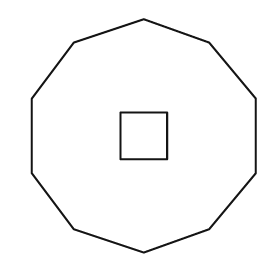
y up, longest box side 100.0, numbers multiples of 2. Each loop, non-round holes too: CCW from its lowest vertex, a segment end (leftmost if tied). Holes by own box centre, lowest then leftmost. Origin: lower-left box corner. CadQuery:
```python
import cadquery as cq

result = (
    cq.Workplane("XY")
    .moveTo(48.0, 0.0)
    .lineTo(76.0, 10.0)
    .lineTo(96.0, 34.0)
    .lineTo(96.0, 66.0)
    .lineTo(76.0, 90.0)
    .lineTo(48.0, 100.0)
    .lineTo(18.0, 90.0)
    .lineTo(0.0, 66.0)
    .lineTo(0.0, 34.0)
    .lineTo(18.0, 10.0)
    .close()
    .moveTo(38.0, 40.0)
    .lineTo(58.0, 40.0)
    .lineTo(58.0, 60.0)
    .lineTo(38.0, 60.0)
    .close()
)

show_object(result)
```